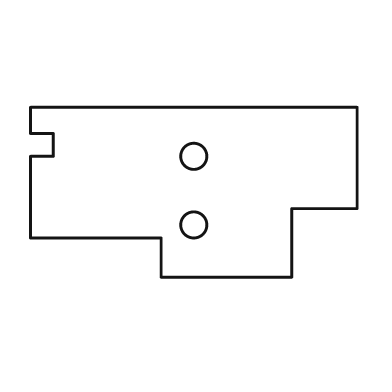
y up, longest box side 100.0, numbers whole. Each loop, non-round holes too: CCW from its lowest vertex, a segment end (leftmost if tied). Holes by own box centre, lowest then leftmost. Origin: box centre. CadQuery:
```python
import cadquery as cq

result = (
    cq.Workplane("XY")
    .moveTo(-10.0, -26.0)
    .lineTo(30.0, -26.0)
    .lineTo(30.0, -5.0)
    .lineTo(50.0, -5.0)
    .lineTo(50.0, 26.0)
    .lineTo(-50.0, 26.0)
    .lineTo(-50.0, 18.0)
    .lineTo(-43.0, 18.0)
    .lineTo(-43.0, 11.0)
    .lineTo(-50.0, 11.0)
    .lineTo(-50.0, -14.0)
    .lineTo(-10.0, -14.0)
    .close()
    .moveTo(0.0, -10.0)
    .circle(4.0)
    .moveTo(0.0, 11.0)
    .circle(4.0)
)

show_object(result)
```